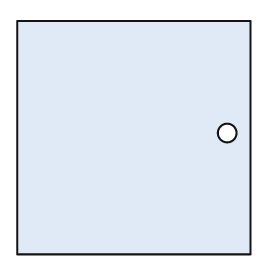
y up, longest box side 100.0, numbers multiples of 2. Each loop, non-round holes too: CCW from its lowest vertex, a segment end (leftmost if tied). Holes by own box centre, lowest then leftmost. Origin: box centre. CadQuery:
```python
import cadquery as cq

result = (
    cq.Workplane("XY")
    .moveTo(-50.0, -50.0)
    .lineTo(50.0, -50.0)
    .lineTo(50.0, 50.0)
    .lineTo(-50.0, 50.0)
    .close()
    .moveTo(40.0, 2.0)
    .circle(4.0)
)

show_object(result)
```